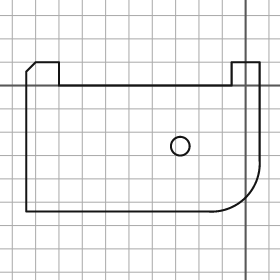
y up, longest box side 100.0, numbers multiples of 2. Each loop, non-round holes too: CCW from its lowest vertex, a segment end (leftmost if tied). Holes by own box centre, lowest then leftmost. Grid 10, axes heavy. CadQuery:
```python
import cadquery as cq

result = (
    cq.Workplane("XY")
    .moveTo(-94.0, -54.0)
    .lineTo(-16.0, -54.0)
    .threePointArc((0.0, -48.0), (6.0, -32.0))
    .lineTo(6.0, 10.0)
    .lineTo(-6.0, 10.0)
    .lineTo(-6.0, 0.0)
    .lineTo(-80.0, 0.0)
    .lineTo(-80.0, 10.0)
    .lineTo(-90.0, 10.0)
    .lineTo(-94.0, 6.0)
    .close()
    .moveTo(-28.0, -26.0)
    .circle(4.0)
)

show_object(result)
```